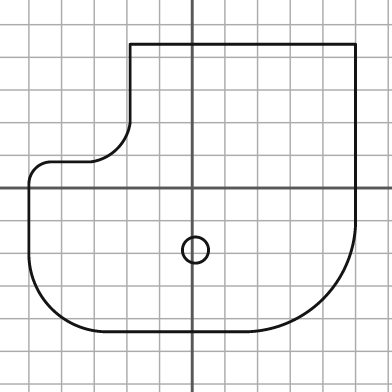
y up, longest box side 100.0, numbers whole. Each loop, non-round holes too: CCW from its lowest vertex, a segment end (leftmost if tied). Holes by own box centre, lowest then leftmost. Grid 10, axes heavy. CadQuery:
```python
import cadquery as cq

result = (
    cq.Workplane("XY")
    .moveTo(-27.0, -44.0)
    .lineTo(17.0, -44.0)
    .threePointArc((40.0, -34.0), (50.0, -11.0))
    .lineTo(50.0, 44.0)
    .lineTo(-19.0, 44.0)
    .lineTo(-19.0, 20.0)
    .threePointArc((-23.0, 12.0), (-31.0, 8.0))
    .lineTo(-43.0, 8.0)
    .threePointArc((-48.0, 6.0), (-50.0, 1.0))
    .lineTo(-50.0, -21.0)
    .threePointArc((-43.0, -37.0), (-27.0, -44.0))
    .close()
    .moveTo(1.0, -19.0)
    .circle(4.0)
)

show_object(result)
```